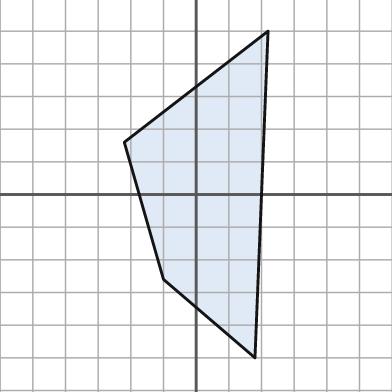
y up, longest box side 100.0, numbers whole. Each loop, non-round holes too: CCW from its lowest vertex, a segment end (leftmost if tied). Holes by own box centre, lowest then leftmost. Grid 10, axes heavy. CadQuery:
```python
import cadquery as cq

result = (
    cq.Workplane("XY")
    .moveTo(18.0, -50.0)
    .lineTo(22.0, 50.0)
    .lineTo(-22.0, 16.0)
    .lineTo(-10.0, -26.0)
    .close()
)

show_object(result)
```